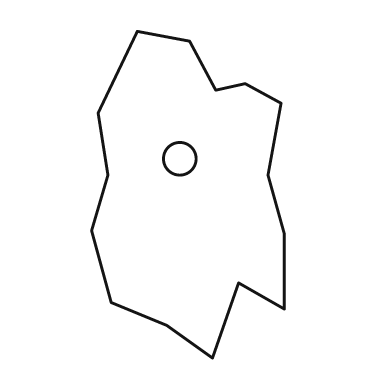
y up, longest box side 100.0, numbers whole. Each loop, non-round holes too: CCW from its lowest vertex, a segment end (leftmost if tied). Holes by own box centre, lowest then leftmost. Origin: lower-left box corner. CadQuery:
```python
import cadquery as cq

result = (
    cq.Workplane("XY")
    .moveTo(37.0, 0.0)
    .lineTo(45.0, 23.0)
    .lineTo(59.0, 15.0)
    .lineTo(59.0, 38.0)
    .lineTo(54.0, 56.0)
    .lineTo(58.0, 78.0)
    .lineTo(47.0, 84.0)
    .lineTo(38.0, 82.0)
    .lineTo(30.0, 97.0)
    .lineTo(14.0, 100.0)
    .lineTo(2.0, 75.0)
    .lineTo(5.0, 56.0)
    .lineTo(0.0, 39.0)
    .lineTo(6.0, 17.0)
    .lineTo(23.0, 10.0)
    .close()
    .moveTo(27.0, 61.0)
    .circle(5.0)
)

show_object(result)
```